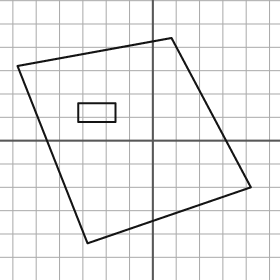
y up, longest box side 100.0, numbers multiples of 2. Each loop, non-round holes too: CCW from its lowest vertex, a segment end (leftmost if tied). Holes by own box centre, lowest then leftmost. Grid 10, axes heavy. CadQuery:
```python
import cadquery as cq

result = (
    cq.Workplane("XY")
    .moveTo(-28.0, -44.0)
    .lineTo(42.0, -20.0)
    .lineTo(8.0, 44.0)
    .lineTo(-58.0, 32.0)
    .close()
    .moveTo(-32.0, 8.0)
    .lineTo(-16.0, 8.0)
    .lineTo(-16.0, 16.0)
    .lineTo(-32.0, 16.0)
    .close()
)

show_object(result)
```